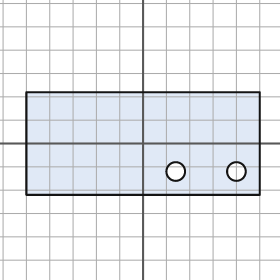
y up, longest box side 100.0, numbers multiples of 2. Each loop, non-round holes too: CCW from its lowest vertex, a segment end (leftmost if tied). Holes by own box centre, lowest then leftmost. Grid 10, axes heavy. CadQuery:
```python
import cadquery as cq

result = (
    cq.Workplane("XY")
    .moveTo(-50.0, -22.0)
    .lineTo(50.0, -22.0)
    .lineTo(50.0, 22.0)
    .lineTo(-50.0, 22.0)
    .close()
    .moveTo(14.0, -12.0)
    .circle(4.0)
    .moveTo(40.0, -12.0)
    .circle(4.0)
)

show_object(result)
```